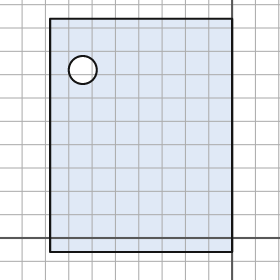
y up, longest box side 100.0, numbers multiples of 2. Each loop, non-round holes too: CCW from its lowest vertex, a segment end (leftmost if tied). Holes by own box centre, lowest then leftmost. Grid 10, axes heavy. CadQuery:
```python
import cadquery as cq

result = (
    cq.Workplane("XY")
    .moveTo(-78.0, -6.0)
    .lineTo(0.0, -6.0)
    .lineTo(0.0, 94.0)
    .lineTo(-78.0, 94.0)
    .close()
    .moveTo(-64.0, 72.0)
    .circle(6.0)
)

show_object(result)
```